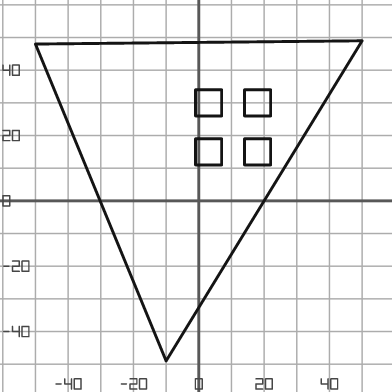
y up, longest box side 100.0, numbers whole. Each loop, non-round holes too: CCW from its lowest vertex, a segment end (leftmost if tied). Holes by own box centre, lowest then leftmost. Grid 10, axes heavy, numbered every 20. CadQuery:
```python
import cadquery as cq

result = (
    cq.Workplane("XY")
    .moveTo(-10.0, -49.0)
    .lineTo(50.0, 49.0)
    .lineTo(-50.0, 48.0)
    .close()
    .moveTo(-1.0, 11.0)
    .lineTo(7.0, 11.0)
    .lineTo(7.0, 19.0)
    .lineTo(-1.0, 19.0)
    .close()
    .moveTo(14.0, 11.0)
    .lineTo(22.0, 11.0)
    .lineTo(22.0, 19.0)
    .lineTo(14.0, 19.0)
    .close()
    .moveTo(-1.0, 26.0)
    .lineTo(7.0, 26.0)
    .lineTo(7.0, 34.0)
    .lineTo(-1.0, 34.0)
    .close()
    .moveTo(14.0, 26.0)
    .lineTo(22.0, 26.0)
    .lineTo(22.0, 34.0)
    .lineTo(14.0, 34.0)
    .close()
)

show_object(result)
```